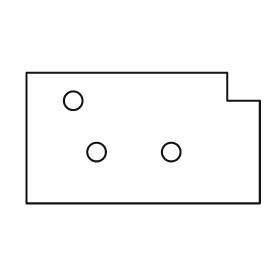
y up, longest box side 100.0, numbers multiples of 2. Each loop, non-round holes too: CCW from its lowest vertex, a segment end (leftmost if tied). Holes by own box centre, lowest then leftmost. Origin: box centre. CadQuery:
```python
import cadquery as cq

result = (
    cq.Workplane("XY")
    .moveTo(-50.0, -28.0)
    .lineTo(50.0, -28.0)
    .lineTo(50.0, 16.0)
    .lineTo(36.0, 16.0)
    .lineTo(36.0, 28.0)
    .lineTo(-50.0, 28.0)
    .close()
    .moveTo(-20.0, -6.0)
    .circle(4.0)
    .moveTo(12.0, -6.0)
    .circle(4.0)
    .moveTo(-30.0, 16.0)
    .circle(4.0)
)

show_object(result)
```